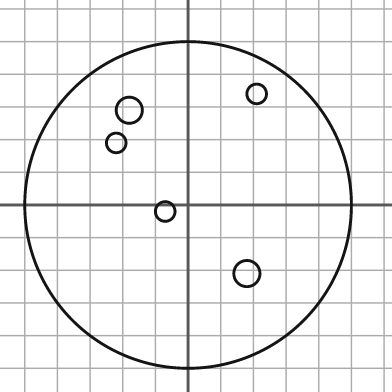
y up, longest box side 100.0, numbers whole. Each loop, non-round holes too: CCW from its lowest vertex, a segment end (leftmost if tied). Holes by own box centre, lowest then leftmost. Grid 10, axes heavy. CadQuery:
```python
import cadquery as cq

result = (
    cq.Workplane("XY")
    .moveTo(0.0, 0.0)
    .circle(50.0)
    .moveTo(18.0, -21.0)
    .circle(4.0)
    .moveTo(-7.0, -2.0)
    .circle(3.0)
    .moveTo(-22.0, 19.0)
    .circle(3.0)
    .moveTo(-18.0, 29.0)
    .circle(4.0)
    .moveTo(21.0, 34.0)
    .circle(3.0)
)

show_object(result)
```